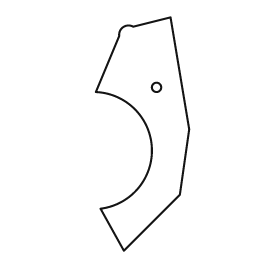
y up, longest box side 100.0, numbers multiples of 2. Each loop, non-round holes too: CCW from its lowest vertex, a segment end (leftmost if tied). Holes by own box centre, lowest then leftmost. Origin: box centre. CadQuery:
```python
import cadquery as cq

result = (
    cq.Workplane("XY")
    .moveTo(-8.0, -50.0)
    .lineTo(16.0, -26.0)
    .lineTo(20.0, 2.0)
    .lineTo(12.0, 50.0)
    .lineTo(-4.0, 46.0)
    .threePointArc((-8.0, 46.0), (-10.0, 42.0))
    .lineTo(-20.0, 18.0)
    .threePointArc((4.0, -6.0), (-18.0, -32.0))
    .close()
    .moveTo(6.0, 20.0)
    .circle(2.0)
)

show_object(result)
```